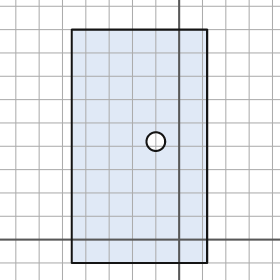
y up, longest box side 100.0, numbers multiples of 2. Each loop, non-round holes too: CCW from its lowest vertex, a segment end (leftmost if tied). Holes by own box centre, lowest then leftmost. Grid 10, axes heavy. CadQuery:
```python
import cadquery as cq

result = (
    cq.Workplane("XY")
    .moveTo(-46.0, -10.0)
    .lineTo(12.0, -10.0)
    .lineTo(12.0, 90.0)
    .lineTo(-46.0, 90.0)
    .close()
    .moveTo(-10.0, 42.0)
    .circle(4.0)
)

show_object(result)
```